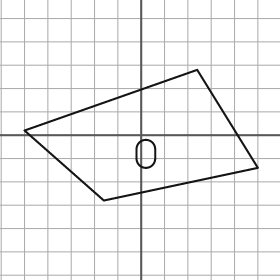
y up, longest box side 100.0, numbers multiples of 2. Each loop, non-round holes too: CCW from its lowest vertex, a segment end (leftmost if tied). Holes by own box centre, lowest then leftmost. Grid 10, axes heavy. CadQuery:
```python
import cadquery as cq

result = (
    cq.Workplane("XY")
    .moveTo(-16.0, -28.0)
    .lineTo(50.0, -14.0)
    .lineTo(24.0, 28.0)
    .lineTo(-50.0, 2.0)
    .close()
    .moveTo(-2.0, -10.0)
    .threePointArc((2.0, -14.0), (6.0, -10.0))
    .lineTo(6.0, -6.0)
    .threePointArc((2.0, -2.0), (-2.0, -6.0))
    .close()
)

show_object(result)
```